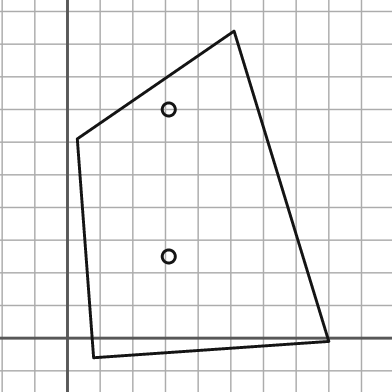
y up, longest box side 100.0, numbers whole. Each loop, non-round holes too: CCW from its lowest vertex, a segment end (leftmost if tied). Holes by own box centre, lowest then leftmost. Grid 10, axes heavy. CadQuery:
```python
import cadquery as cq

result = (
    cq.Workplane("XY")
    .moveTo(8.0, -6.0)
    .lineTo(80.0, -1.0)
    .lineTo(51.0, 94.0)
    .lineTo(3.0, 61.0)
    .close()
    .moveTo(31.0, 25.0)
    .circle(2.0)
    .moveTo(31.0, 70.0)
    .circle(2.0)
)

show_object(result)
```